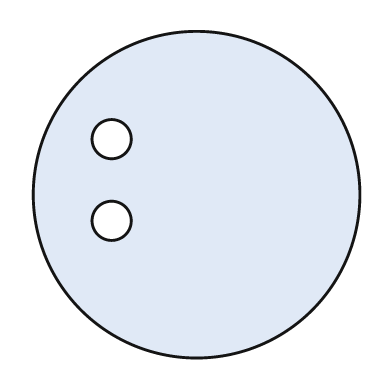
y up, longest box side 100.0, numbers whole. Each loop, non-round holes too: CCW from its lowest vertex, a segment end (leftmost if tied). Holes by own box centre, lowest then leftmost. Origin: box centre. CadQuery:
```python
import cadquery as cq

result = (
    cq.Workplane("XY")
    .moveTo(0.0, 0.0)
    .circle(50.0)
    .moveTo(-26.0, -8.0)
    .circle(6.0)
    .moveTo(-26.0, 17.0)
    .circle(6.0)
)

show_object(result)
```